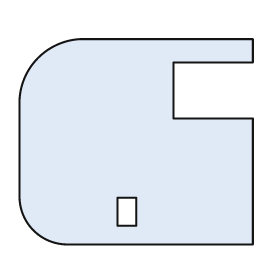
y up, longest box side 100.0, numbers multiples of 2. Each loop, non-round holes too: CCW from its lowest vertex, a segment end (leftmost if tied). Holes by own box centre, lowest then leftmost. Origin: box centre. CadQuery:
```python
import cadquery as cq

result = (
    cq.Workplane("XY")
    .moveTo(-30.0, -44.0)
    .lineTo(50.0, -44.0)
    .lineTo(50.0, 10.0)
    .lineTo(16.0, 10.0)
    .lineTo(16.0, 34.0)
    .lineTo(50.0, 34.0)
    .lineTo(50.0, 44.0)
    .lineTo(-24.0, 44.0)
    .threePointArc((-42.0, 36.0), (-50.0, 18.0))
    .lineTo(-50.0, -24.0)
    .threePointArc((-44.0, -38.0), (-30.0, -44.0))
    .close()
    .moveTo(-8.0, -36.0)
    .lineTo(0.0, -36.0)
    .lineTo(0.0, -24.0)
    .lineTo(-8.0, -24.0)
    .close()
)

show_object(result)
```